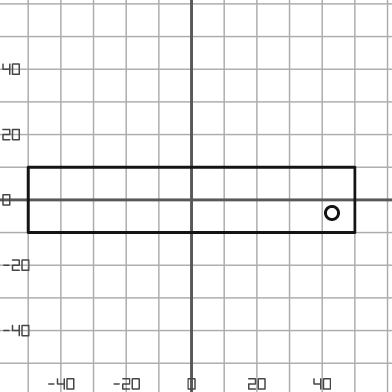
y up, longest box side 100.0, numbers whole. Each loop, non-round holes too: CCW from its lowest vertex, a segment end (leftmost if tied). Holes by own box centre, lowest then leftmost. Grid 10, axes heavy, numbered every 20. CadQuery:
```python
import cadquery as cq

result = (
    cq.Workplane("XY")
    .moveTo(-50.0, -10.0)
    .lineTo(50.0, -10.0)
    .lineTo(50.0, 10.0)
    .lineTo(-50.0, 10.0)
    .close()
    .moveTo(43.0, -4.0)
    .circle(2.0)
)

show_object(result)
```